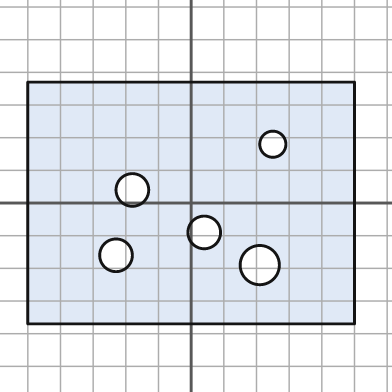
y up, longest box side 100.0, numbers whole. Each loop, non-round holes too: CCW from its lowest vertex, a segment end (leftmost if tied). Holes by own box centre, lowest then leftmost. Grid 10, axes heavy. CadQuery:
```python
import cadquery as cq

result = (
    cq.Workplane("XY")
    .moveTo(-50.0, -37.0)
    .lineTo(50.0, -37.0)
    .lineTo(50.0, 37.0)
    .lineTo(-50.0, 37.0)
    .close()
    .moveTo(21.0, -19.0)
    .circle(6.0)
    .moveTo(-23.0, -16.0)
    .circle(5.0)
    .moveTo(4.0, -9.0)
    .circle(5.0)
    .moveTo(-18.0, 4.0)
    .circle(5.0)
    .moveTo(25.0, 18.0)
    .circle(4.0)
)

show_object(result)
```